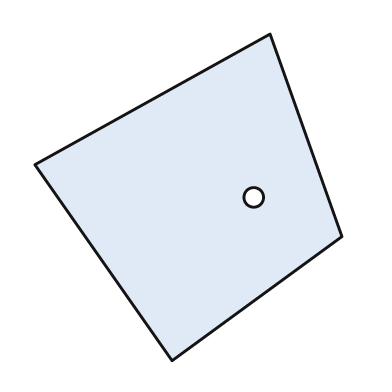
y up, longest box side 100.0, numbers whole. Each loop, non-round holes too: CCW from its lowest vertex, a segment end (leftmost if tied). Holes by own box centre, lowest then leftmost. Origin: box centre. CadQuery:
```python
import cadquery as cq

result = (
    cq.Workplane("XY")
    .moveTo(-5.0, -50.0)
    .lineTo(47.0, -12.0)
    .lineTo(25.0, 50.0)
    .lineTo(-47.0, 10.0)
    .close()
    .moveTo(20.0, 0.0)
    .circle(3.0)
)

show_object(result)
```